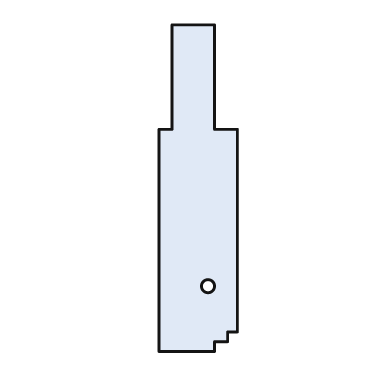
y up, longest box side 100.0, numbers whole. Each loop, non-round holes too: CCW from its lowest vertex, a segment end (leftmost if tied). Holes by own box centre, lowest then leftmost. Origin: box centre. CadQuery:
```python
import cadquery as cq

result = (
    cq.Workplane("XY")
    .moveTo(-12.0, -50.0)
    .lineTo(5.0, -50.0)
    .lineTo(5.0, -47.0)
    .lineTo(9.0, -47.0)
    .lineTo(9.0, -44.0)
    .lineTo(12.0, -44.0)
    .lineTo(12.0, 18.0)
    .lineTo(5.0, 18.0)
    .lineTo(5.0, 50.0)
    .lineTo(-8.0, 50.0)
    .lineTo(-8.0, 18.0)
    .lineTo(-12.0, 18.0)
    .close()
    .moveTo(3.0, -30.0)
    .circle(2.0)
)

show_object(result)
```